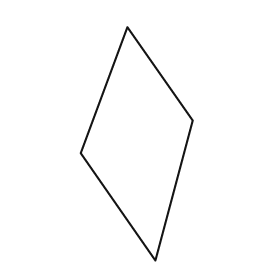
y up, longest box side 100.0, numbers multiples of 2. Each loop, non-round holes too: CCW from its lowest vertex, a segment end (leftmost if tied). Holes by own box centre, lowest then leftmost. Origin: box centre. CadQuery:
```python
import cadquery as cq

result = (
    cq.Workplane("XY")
    .moveTo(8.0, -50.0)
    .lineTo(24.0, 10.0)
    .lineTo(-4.0, 50.0)
    .lineTo(-24.0, -4.0)
    .close()
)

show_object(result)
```